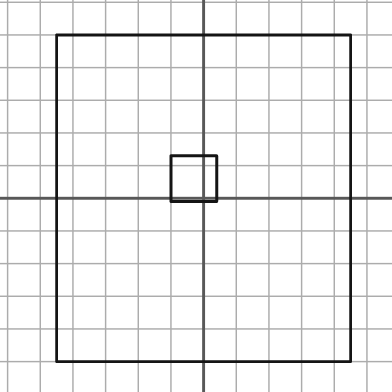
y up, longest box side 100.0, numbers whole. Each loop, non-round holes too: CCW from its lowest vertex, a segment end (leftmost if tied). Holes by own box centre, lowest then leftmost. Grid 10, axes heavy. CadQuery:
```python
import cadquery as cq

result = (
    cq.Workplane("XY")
    .moveTo(-45.0, -50.0)
    .lineTo(45.0, -50.0)
    .lineTo(45.0, 50.0)
    .lineTo(-45.0, 50.0)
    .close()
    .moveTo(-10.0, -1.0)
    .lineTo(4.0, -1.0)
    .lineTo(4.0, 13.0)
    .lineTo(-10.0, 13.0)
    .close()
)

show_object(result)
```